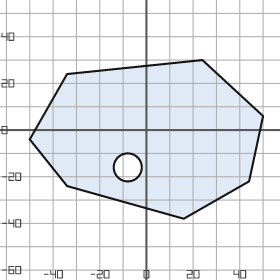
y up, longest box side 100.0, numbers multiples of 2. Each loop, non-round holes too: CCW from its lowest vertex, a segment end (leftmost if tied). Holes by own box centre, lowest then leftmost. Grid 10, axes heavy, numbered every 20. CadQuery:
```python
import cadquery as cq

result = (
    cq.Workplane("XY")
    .moveTo(16.0, -38.0)
    .lineTo(44.0, -22.0)
    .lineTo(50.0, 6.0)
    .lineTo(24.0, 30.0)
    .lineTo(-34.0, 24.0)
    .lineTo(-50.0, -4.0)
    .lineTo(-34.0, -24.0)
    .close()
    .moveTo(-8.0, -16.0)
    .circle(6.0)
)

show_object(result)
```